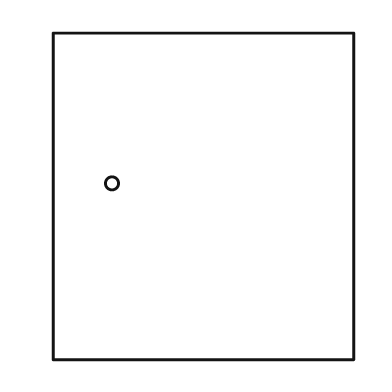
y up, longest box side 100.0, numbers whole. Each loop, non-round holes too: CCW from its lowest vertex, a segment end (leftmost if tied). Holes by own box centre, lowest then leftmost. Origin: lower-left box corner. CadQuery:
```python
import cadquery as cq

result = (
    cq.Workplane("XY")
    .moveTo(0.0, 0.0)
    .lineTo(92.0, 0.0)
    .lineTo(92.0, 100.0)
    .lineTo(0.0, 100.0)
    .close()
    .moveTo(18.0, 54.0)
    .circle(2.0)
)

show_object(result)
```